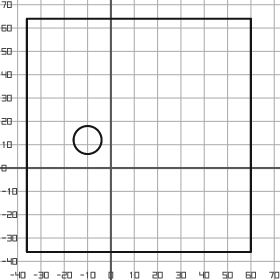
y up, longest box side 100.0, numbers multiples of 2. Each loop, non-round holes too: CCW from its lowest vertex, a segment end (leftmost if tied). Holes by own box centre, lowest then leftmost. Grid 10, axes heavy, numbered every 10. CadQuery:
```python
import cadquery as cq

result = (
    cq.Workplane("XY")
    .moveTo(-36.0, -36.0)
    .lineTo(60.0, -36.0)
    .lineTo(60.0, 64.0)
    .lineTo(-36.0, 64.0)
    .close()
    .moveTo(-10.0, 12.0)
    .circle(6.0)
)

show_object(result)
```